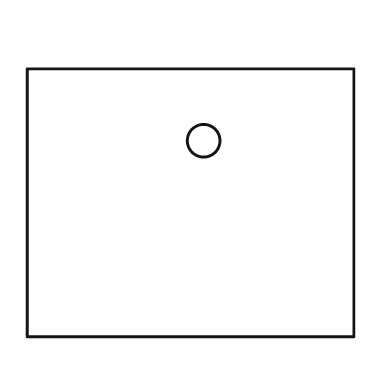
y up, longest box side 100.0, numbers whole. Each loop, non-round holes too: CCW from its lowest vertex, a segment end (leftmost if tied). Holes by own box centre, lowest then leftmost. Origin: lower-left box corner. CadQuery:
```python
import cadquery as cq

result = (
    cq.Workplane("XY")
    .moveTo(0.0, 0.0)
    .lineTo(100.0, 0.0)
    .lineTo(100.0, 82.0)
    .lineTo(0.0, 82.0)
    .close()
    .moveTo(54.0, 60.0)
    .circle(5.0)
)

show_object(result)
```